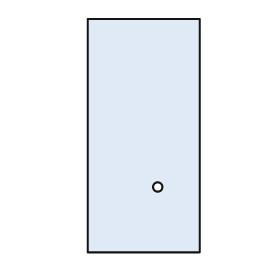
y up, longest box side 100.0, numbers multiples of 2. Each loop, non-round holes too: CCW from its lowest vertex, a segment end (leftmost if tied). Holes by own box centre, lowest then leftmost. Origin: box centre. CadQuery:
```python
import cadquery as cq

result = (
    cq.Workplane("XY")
    .moveTo(-24.0, -50.0)
    .lineTo(24.0, -50.0)
    .lineTo(24.0, 50.0)
    .lineTo(-24.0, 50.0)
    .close()
    .moveTo(6.0, -22.0)
    .circle(2.0)
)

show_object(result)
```